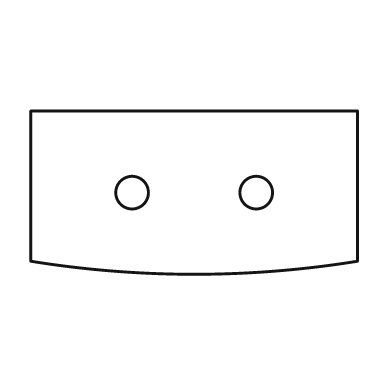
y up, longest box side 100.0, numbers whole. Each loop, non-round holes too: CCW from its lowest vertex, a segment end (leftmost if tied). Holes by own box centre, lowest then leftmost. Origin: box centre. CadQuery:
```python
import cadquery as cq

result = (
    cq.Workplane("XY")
    .moveTo(-50.0, -21.0)
    .threePointArc((0.0, -25.0), (50.0, -21.0))
    .lineTo(50.0, 25.0)
    .lineTo(-50.0, 25.0)
    .close()
    .moveTo(-19.0, 0.0)
    .circle(5.0)
    .moveTo(19.0, 0.0)
    .circle(5.0)
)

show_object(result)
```